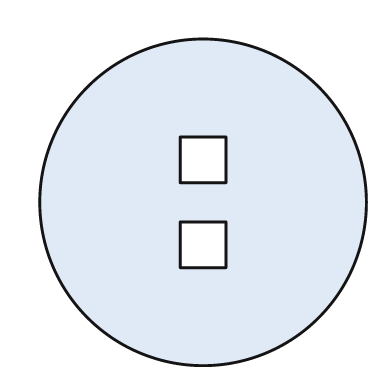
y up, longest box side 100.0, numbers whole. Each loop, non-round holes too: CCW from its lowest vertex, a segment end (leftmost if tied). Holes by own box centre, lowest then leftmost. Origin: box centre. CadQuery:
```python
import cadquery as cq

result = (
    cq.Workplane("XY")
    .moveTo(0.0, 0.0)
    .circle(50.0)
    .moveTo(-7.0, -20.0)
    .lineTo(7.0, -20.0)
    .lineTo(7.0, -6.0)
    .lineTo(-7.0, -6.0)
    .close()
    .moveTo(-7.0, 6.0)
    .lineTo(7.0, 6.0)
    .lineTo(7.0, 20.0)
    .lineTo(-7.0, 20.0)
    .close()
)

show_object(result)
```